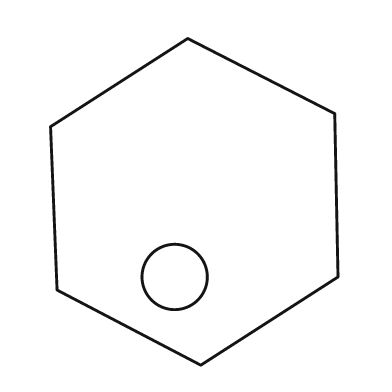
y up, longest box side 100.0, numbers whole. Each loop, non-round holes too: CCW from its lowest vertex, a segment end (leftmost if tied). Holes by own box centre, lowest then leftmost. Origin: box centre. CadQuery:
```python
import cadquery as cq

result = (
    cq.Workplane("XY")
    .moveTo(2.0, -50.0)
    .lineTo(44.0, -23.0)
    .lineTo(43.0, 27.0)
    .lineTo(-2.0, 50.0)
    .lineTo(-44.0, 23.0)
    .lineTo(-42.0, -27.0)
    .close()
    .moveTo(-6.0, -23.0)
    .circle(10.0)
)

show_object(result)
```